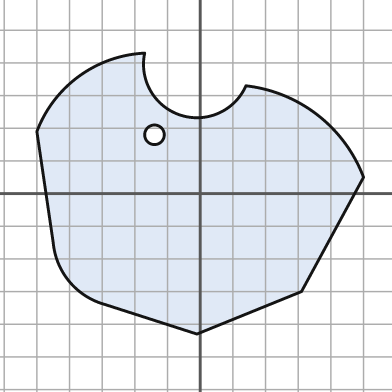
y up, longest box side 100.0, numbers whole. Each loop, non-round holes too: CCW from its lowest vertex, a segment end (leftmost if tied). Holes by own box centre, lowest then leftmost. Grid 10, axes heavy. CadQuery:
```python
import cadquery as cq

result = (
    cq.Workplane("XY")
    .moveTo(-1.0, -43.0)
    .lineTo(31.0, -30.0)
    .lineTo(50.0, 5.0)
    .threePointArc((36.0, 24.0), (14.0, 33.0))
    .threePointArc((-6.0, 24.0), (-17.0, 43.0))
    .threePointArc((-37.0, 36.0), (-50.0, 19.0))
    .lineTo(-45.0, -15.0)
    .threePointArc((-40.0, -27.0), (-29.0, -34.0))
    .close()
    .moveTo(-14.0, 18.0)
    .circle(3.0)
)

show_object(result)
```